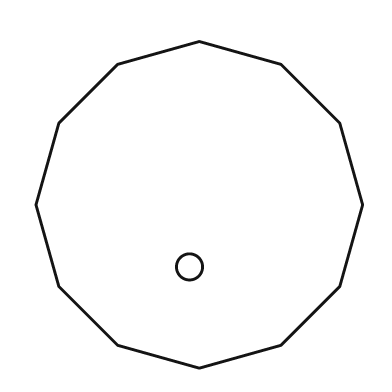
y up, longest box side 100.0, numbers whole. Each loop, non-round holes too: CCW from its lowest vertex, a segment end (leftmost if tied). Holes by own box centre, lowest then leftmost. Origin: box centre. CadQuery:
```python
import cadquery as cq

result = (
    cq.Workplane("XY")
    .moveTo(0.0, -50.0)
    .lineTo(25.0, -43.0)
    .lineTo(43.0, -25.0)
    .lineTo(50.0, 0.0)
    .lineTo(43.0, 25.0)
    .lineTo(25.0, 43.0)
    .lineTo(0.0, 50.0)
    .lineTo(-25.0, 43.0)
    .lineTo(-43.0, 25.0)
    .lineTo(-50.0, 0.0)
    .lineTo(-43.0, -25.0)
    .lineTo(-25.0, -43.0)
    .close()
    .moveTo(-3.0, -19.0)
    .circle(4.0)
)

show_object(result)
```